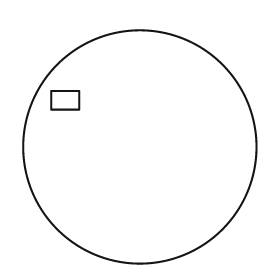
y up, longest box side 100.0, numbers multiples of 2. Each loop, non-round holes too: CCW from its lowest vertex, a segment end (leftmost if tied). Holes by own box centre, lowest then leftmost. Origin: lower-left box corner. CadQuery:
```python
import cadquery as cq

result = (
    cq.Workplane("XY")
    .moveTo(50.0, 50.0)
    .circle(50.0)
    .moveTo(12.0, 66.0)
    .lineTo(24.0, 66.0)
    .lineTo(24.0, 74.0)
    .lineTo(12.0, 74.0)
    .close()
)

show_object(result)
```